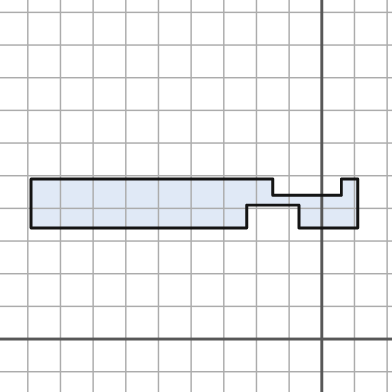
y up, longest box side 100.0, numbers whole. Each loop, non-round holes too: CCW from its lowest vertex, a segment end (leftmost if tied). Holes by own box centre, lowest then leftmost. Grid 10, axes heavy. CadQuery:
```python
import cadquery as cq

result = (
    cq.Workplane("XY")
    .moveTo(-89.0, 34.0)
    .lineTo(-23.0, 34.0)
    .lineTo(-23.0, 41.0)
    .lineTo(-7.0, 41.0)
    .lineTo(-7.0, 34.0)
    .lineTo(11.0, 34.0)
    .lineTo(11.0, 49.0)
    .lineTo(6.0, 49.0)
    .lineTo(6.0, 44.0)
    .lineTo(-15.0, 44.0)
    .lineTo(-15.0, 49.0)
    .lineTo(-89.0, 49.0)
    .close()
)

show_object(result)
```